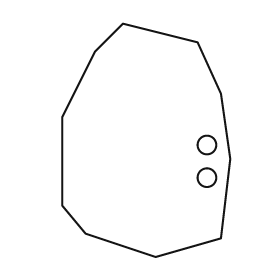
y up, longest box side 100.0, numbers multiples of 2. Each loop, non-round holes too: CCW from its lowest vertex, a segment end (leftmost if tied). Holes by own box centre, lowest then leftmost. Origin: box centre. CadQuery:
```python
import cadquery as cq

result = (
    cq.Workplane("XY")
    .moveTo(4.0, -50.0)
    .lineTo(32.0, -42.0)
    .lineTo(36.0, -8.0)
    .lineTo(32.0, 20.0)
    .lineTo(22.0, 42.0)
    .lineTo(-10.0, 50.0)
    .lineTo(-22.0, 38.0)
    .lineTo(-36.0, 10.0)
    .lineTo(-36.0, -28.0)
    .lineTo(-26.0, -40.0)
    .close()
    .moveTo(26.0, -16.0)
    .circle(4.0)
    .moveTo(26.0, -2.0)
    .circle(4.0)
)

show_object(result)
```